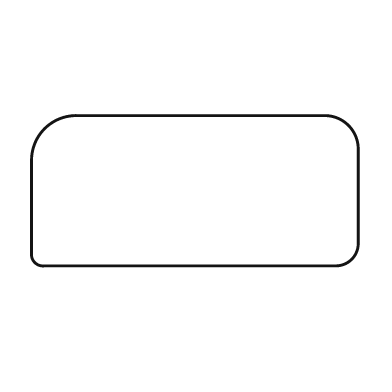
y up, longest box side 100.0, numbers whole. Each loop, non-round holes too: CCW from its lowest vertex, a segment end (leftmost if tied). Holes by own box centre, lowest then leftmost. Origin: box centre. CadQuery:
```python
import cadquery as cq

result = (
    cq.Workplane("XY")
    .moveTo(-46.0, -23.0)
    .lineTo(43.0, -23.0)
    .threePointArc((48.0, -21.0), (50.0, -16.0))
    .lineTo(50.0, 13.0)
    .threePointArc((47.0, 20.0), (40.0, 23.0))
    .lineTo(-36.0, 23.0)
    .threePointArc((-46.0, 19.0), (-50.0, 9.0))
    .lineTo(-50.0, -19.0)
    .threePointArc((-49.0, -22.0), (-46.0, -23.0))
    .close()
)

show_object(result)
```